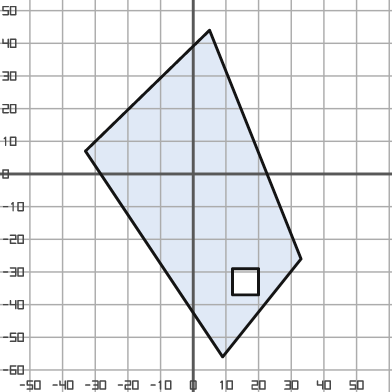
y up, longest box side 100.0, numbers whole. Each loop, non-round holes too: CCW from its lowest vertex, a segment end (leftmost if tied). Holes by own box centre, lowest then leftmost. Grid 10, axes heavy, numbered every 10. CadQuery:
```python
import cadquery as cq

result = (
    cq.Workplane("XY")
    .moveTo(9.0, -56.0)
    .lineTo(33.0, -26.0)
    .lineTo(5.0, 44.0)
    .lineTo(-33.0, 7.0)
    .close()
    .moveTo(12.0, -37.0)
    .lineTo(20.0, -37.0)
    .lineTo(20.0, -29.0)
    .lineTo(12.0, -29.0)
    .close()
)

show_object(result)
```